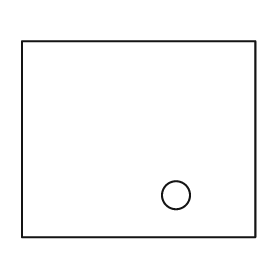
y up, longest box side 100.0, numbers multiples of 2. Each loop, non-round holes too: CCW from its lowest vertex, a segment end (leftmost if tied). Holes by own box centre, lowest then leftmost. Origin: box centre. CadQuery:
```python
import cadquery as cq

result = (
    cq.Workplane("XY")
    .moveTo(-50.0, -42.0)
    .lineTo(50.0, -42.0)
    .lineTo(50.0, 42.0)
    .lineTo(-50.0, 42.0)
    .close()
    .moveTo(16.0, -24.0)
    .circle(6.0)
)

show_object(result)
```